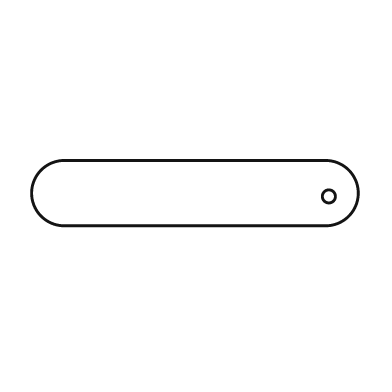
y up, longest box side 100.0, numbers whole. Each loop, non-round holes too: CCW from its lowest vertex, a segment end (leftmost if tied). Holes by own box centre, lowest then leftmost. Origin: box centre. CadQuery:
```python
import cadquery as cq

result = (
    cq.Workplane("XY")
    .moveTo(-40.0, -10.0)
    .lineTo(40.0, -10.0)
    .threePointArc((50.0, 0.0), (40.0, 10.0))
    .lineTo(-40.0, 10.0)
    .threePointArc((-50.0, 0.0), (-40.0, -10.0))
    .close()
    .moveTo(41.0, -1.0)
    .circle(2.0)
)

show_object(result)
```